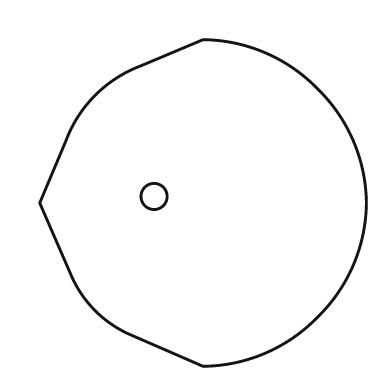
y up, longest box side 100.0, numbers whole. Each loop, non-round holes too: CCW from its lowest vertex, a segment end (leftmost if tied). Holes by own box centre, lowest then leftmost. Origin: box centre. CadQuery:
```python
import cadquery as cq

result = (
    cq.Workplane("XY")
    .moveTo(0.0, -50.0)
    .threePointArc((19.0, -46.0), (35.0, -35.0))
    .threePointArc((46.0, -19.0), (50.0, 0.0))
    .threePointArc((46.0, 19.0), (35.0, 35.0))
    .threePointArc((19.0, 46.0), (0.0, 50.0))
    .lineTo(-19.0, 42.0)
    .threePointArc((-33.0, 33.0), (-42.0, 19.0))
    .lineTo(-50.0, 0.0)
    .lineTo(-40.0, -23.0)
    .threePointArc((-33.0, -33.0), (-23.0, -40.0))
    .close()
    .moveTo(-15.0, 2.0)
    .circle(4.0)
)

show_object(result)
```